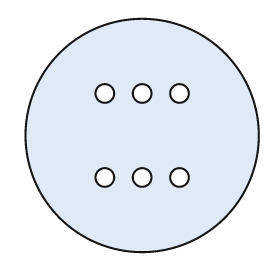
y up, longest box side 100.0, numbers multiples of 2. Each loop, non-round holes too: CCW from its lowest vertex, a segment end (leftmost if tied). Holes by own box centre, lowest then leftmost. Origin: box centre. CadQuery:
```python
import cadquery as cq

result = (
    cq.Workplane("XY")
    .moveTo(0.0, 0.0)
    .circle(50.0)
    .moveTo(-16.0, -18.0)
    .circle(4.0)
    .moveTo(0.0, -18.0)
    .circle(4.0)
    .moveTo(16.0, -18.0)
    .circle(4.0)
    .moveTo(-16.0, 18.0)
    .circle(4.0)
    .moveTo(0.0, 18.0)
    .circle(4.0)
    .moveTo(16.0, 18.0)
    .circle(4.0)
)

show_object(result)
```